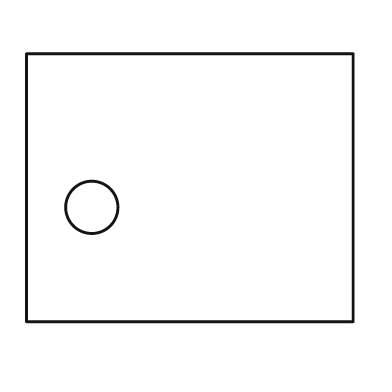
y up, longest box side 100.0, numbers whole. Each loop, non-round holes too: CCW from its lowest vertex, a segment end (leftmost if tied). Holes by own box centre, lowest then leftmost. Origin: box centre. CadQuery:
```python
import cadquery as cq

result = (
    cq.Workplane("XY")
    .moveTo(-50.0, -41.0)
    .lineTo(50.0, -41.0)
    .lineTo(50.0, 41.0)
    .lineTo(-50.0, 41.0)
    .close()
    .moveTo(-30.0, -6.0)
    .circle(8.0)
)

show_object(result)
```